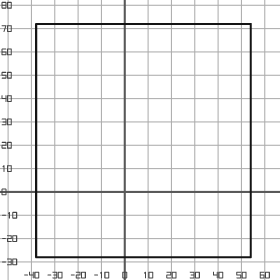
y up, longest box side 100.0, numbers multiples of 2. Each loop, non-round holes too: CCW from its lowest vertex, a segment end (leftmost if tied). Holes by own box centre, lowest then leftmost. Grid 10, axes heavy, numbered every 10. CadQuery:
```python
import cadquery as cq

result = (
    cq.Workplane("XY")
    .moveTo(-38.0, -28.0)
    .lineTo(54.0, -28.0)
    .lineTo(54.0, 72.0)
    .lineTo(-38.0, 72.0)
    .close()
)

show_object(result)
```